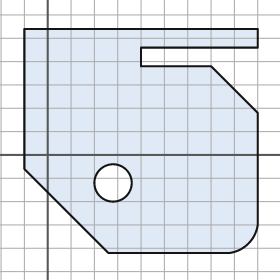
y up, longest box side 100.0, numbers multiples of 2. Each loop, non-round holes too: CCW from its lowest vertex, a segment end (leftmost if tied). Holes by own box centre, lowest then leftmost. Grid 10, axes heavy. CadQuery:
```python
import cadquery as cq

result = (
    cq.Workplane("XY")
    .moveTo(26.0, -42.0)
    .lineTo(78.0, -42.0)
    .threePointArc((86.0, -38.0), (90.0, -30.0))
    .lineTo(90.0, 18.0)
    .lineTo(70.0, 38.0)
    .lineTo(40.0, 38.0)
    .lineTo(40.0, 46.0)
    .lineTo(90.0, 46.0)
    .lineTo(90.0, 54.0)
    .lineTo(-10.0, 54.0)
    .lineTo(-10.0, -6.0)
    .close()
    .moveTo(28.0, -12.0)
    .circle(8.0)
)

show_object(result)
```